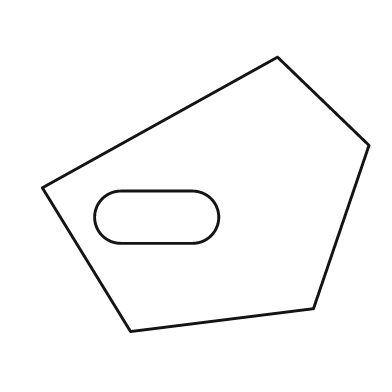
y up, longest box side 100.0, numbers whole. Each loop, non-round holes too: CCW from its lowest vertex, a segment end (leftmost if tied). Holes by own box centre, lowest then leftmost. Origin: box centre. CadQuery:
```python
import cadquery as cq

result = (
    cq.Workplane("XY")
    .moveTo(-23.0, -42.0)
    .lineTo(33.0, -35.0)
    .lineTo(50.0, 15.0)
    .lineTo(22.0, 42.0)
    .lineTo(-50.0, 2.0)
    .close()
    .moveTo(-26.0, -15.0)
    .lineTo(-4.0, -15.0)
    .threePointArc((4.0, -7.0), (-4.0, 1.0))
    .lineTo(-26.0, 1.0)
    .threePointArc((-34.0, -7.0), (-26.0, -15.0))
    .close()
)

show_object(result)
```